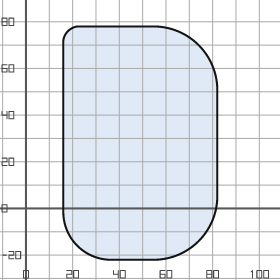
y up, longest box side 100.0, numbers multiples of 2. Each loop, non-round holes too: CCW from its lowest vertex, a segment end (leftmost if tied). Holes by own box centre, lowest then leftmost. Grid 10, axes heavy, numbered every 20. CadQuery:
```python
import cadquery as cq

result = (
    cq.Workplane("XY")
    .moveTo(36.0, -22.0)
    .lineTo(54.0, -22.0)
    .threePointArc((74.0, -14.0), (82.0, 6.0))
    .lineTo(82.0, 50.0)
    .threePointArc((74.0, 70.0), (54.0, 78.0))
    .lineTo(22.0, 78.0)
    .threePointArc((18.0, 76.0), (16.0, 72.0))
    .lineTo(16.0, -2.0)
    .threePointArc((22.0, -16.0), (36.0, -22.0))
    .close()
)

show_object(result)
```